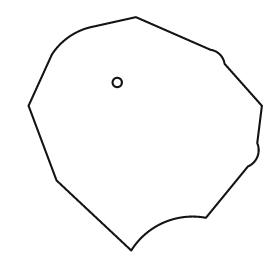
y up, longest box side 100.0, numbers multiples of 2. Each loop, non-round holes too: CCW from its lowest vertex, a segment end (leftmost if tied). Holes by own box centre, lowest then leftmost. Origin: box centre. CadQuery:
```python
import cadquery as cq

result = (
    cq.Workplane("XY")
    .moveTo(-6.0, -50.0)
    .threePointArc((8.0, -38.0), (26.0, -36.0))
    .lineTo(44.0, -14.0)
    .threePointArc((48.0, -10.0), (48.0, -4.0))
    .lineTo(50.0, 12.0)
    .lineTo(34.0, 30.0)
    .threePointArc((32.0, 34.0), (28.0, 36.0))
    .lineTo(-4.0, 50.0)
    .lineTo(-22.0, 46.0)
    .threePointArc((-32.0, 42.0), (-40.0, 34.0))
    .lineTo(-50.0, 12.0)
    .lineTo(-38.0, -20.0)
    .close()
    .moveTo(-12.0, 22.0)
    .circle(2.0)
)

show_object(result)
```